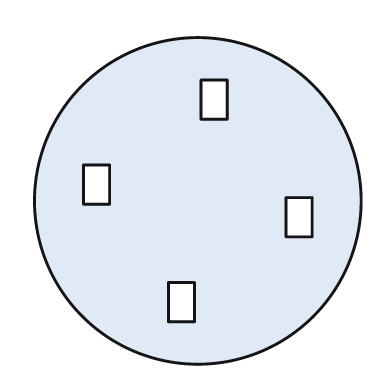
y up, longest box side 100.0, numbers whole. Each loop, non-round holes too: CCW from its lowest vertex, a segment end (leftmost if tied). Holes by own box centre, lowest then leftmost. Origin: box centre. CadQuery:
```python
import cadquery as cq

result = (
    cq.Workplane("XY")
    .moveTo(0.0, 0.0)
    .circle(50.0)
    .moveTo(-9.0, -37.0)
    .lineTo(-1.0, -37.0)
    .lineTo(-1.0, -25.0)
    .lineTo(-9.0, -25.0)
    .close()
    .moveTo(27.0, -11.0)
    .lineTo(35.0, -11.0)
    .lineTo(35.0, 1.0)
    .lineTo(27.0, 1.0)
    .close()
    .moveTo(-35.0, -1.0)
    .lineTo(-27.0, -1.0)
    .lineTo(-27.0, 11.0)
    .lineTo(-35.0, 11.0)
    .close()
    .moveTo(1.0, 25.0)
    .lineTo(9.0, 25.0)
    .lineTo(9.0, 37.0)
    .lineTo(1.0, 37.0)
    .close()
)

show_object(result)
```